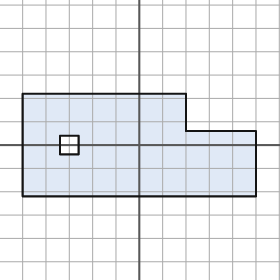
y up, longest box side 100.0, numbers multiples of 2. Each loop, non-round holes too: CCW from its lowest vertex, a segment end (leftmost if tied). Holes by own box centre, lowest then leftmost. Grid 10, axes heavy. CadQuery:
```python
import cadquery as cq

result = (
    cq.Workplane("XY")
    .moveTo(-50.0, -22.0)
    .lineTo(50.0, -22.0)
    .lineTo(50.0, 6.0)
    .lineTo(20.0, 6.0)
    .lineTo(20.0, 22.0)
    .lineTo(-50.0, 22.0)
    .close()
    .moveTo(-34.0, -4.0)
    .lineTo(-26.0, -4.0)
    .lineTo(-26.0, 4.0)
    .lineTo(-34.0, 4.0)
    .close()
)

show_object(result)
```